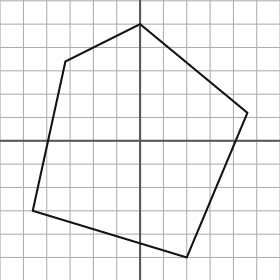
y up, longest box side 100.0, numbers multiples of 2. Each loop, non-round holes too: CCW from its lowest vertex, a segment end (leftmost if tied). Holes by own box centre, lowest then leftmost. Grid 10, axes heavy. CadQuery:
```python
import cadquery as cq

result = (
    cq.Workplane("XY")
    .moveTo(20.0, -50.0)
    .lineTo(46.0, 12.0)
    .lineTo(0.0, 50.0)
    .lineTo(-32.0, 34.0)
    .lineTo(-46.0, -30.0)
    .close()
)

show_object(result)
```